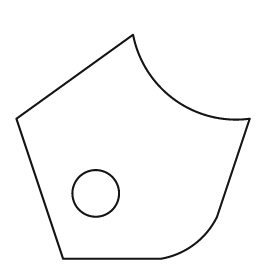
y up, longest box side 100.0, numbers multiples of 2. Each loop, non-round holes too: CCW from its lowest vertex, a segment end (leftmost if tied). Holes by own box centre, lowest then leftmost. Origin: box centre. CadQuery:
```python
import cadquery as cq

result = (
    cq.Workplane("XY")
    .moveTo(-30.0, -48.0)
    .lineTo(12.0, -48.0)
    .threePointArc((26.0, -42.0), (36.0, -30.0))
    .lineTo(50.0, 12.0)
    .threePointArc((18.0, 20.0), (0.0, 48.0))
    .lineTo(-50.0, 12.0)
    .close()
    .moveTo(-16.0, -20.0)
    .circle(10.0)
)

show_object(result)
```